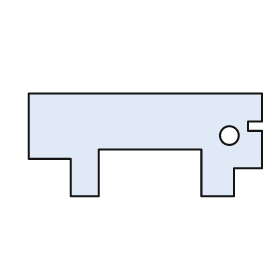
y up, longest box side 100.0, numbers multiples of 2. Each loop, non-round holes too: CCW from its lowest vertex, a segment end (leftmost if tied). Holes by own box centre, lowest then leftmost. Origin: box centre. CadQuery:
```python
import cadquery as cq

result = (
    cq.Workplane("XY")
    .moveTo(-32.0, -22.0)
    .lineTo(-20.0, -22.0)
    .lineTo(-20.0, -2.0)
    .lineTo(24.0, -2.0)
    .lineTo(24.0, -22.0)
    .lineTo(38.0, -22.0)
    .lineTo(38.0, -10.0)
    .lineTo(50.0, -10.0)
    .lineTo(50.0, 6.0)
    .lineTo(44.0, 6.0)
    .lineTo(44.0, 10.0)
    .lineTo(50.0, 10.0)
    .lineTo(50.0, 22.0)
    .lineTo(-50.0, 22.0)
    .lineTo(-50.0, -6.0)
    .lineTo(-32.0, -6.0)
    .close()
    .moveTo(36.0, 4.0)
    .circle(4.0)
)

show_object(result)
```